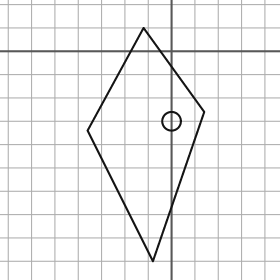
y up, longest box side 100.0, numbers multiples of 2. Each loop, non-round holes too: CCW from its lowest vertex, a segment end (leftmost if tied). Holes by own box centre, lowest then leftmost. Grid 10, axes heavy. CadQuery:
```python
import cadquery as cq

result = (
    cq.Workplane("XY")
    .moveTo(-8.0, -90.0)
    .lineTo(14.0, -26.0)
    .lineTo(-12.0, 10.0)
    .lineTo(-36.0, -34.0)
    .close()
    .moveTo(0.0, -30.0)
    .circle(4.0)
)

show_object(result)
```